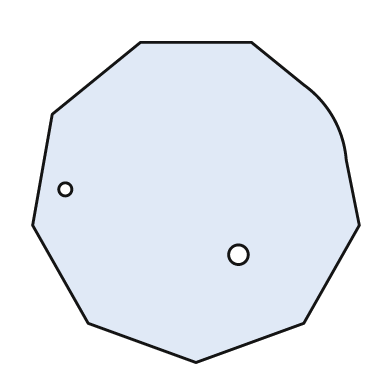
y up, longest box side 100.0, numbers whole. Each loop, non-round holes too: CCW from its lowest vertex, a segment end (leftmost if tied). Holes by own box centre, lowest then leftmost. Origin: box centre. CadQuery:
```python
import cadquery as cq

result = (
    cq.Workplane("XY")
    .moveTo(0.0, -49.0)
    .lineTo(33.0, -37.0)
    .lineTo(50.0, -7.0)
    .lineTo(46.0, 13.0)
    .threePointArc((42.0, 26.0), (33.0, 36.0))
    .lineTo(17.0, 49.0)
    .lineTo(-17.0, 49.0)
    .lineTo(-44.0, 27.0)
    .lineTo(-50.0, -7.0)
    .lineTo(-33.0, -37.0)
    .close()
    .moveTo(13.0, -16.0)
    .circle(3.0)
    .moveTo(-40.0, 4.0)
    .circle(2.0)
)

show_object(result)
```